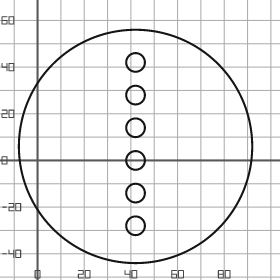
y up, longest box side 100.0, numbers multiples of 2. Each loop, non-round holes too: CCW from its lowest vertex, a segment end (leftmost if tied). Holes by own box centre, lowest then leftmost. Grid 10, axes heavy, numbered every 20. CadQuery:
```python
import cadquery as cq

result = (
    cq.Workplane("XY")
    .moveTo(42.0, 6.0)
    .circle(50.0)
    .moveTo(42.0, -28.0)
    .circle(4.0)
    .moveTo(42.0, -14.0)
    .circle(4.0)
    .moveTo(42.0, 0.0)
    .circle(4.0)
    .moveTo(42.0, 14.0)
    .circle(4.0)
    .moveTo(42.0, 28.0)
    .circle(4.0)
    .moveTo(42.0, 42.0)
    .circle(4.0)
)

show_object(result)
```